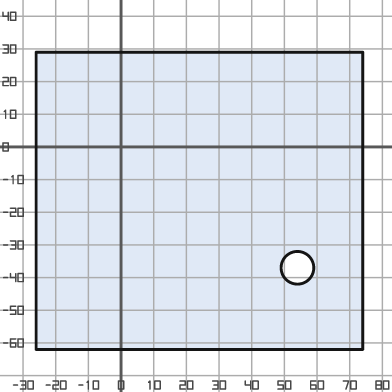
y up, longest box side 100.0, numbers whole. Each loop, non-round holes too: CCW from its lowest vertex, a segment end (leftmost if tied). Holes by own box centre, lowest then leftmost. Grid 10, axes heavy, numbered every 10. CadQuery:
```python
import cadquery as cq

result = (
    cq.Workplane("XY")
    .moveTo(-26.0, -62.0)
    .lineTo(74.0, -62.0)
    .lineTo(74.0, 29.0)
    .lineTo(-26.0, 29.0)
    .close()
    .moveTo(54.0, -37.0)
    .circle(5.0)
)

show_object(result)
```